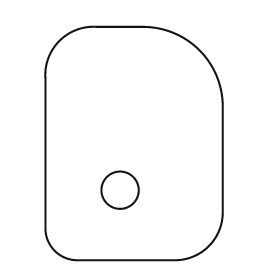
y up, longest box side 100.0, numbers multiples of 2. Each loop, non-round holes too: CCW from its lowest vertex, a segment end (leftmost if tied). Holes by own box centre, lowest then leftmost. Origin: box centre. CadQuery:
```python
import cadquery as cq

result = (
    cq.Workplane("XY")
    .moveTo(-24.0, -50.0)
    .lineTo(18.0, -50.0)
    .threePointArc((32.0, -44.0), (38.0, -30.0))
    .lineTo(38.0, 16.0)
    .threePointArc((28.0, 40.0), (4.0, 50.0))
    .lineTo(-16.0, 50.0)
    .threePointArc((-32.0, 44.0), (-38.0, 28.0))
    .lineTo(-38.0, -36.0)
    .threePointArc((-34.0, -46.0), (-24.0, -50.0))
    .close()
    .moveTo(-6.0, -20.0)
    .circle(8.0)
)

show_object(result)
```